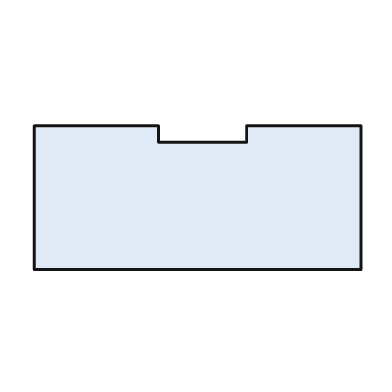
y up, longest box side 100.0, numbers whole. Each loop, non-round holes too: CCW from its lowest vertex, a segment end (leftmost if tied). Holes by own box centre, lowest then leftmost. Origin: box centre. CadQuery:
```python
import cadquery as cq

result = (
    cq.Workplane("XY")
    .moveTo(-50.0, -22.0)
    .lineTo(50.0, -22.0)
    .lineTo(50.0, 22.0)
    .lineTo(15.0, 22.0)
    .lineTo(15.0, 17.0)
    .lineTo(-12.0, 17.0)
    .lineTo(-12.0, 22.0)
    .lineTo(-50.0, 22.0)
    .close()
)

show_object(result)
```